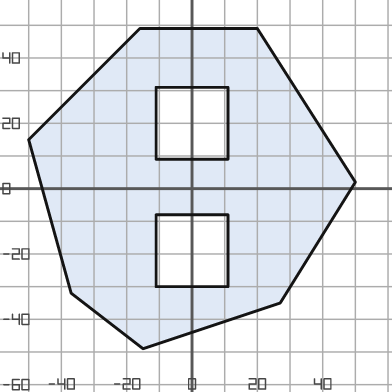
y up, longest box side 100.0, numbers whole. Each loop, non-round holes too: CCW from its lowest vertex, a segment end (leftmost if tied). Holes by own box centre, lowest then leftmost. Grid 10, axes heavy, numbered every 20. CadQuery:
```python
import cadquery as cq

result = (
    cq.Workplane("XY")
    .moveTo(-15.0, -49.0)
    .lineTo(27.0, -35.0)
    .lineTo(50.0, 2.0)
    .lineTo(20.0, 49.0)
    .lineTo(-16.0, 49.0)
    .lineTo(-50.0, 15.0)
    .lineTo(-37.0, -32.0)
    .close()
    .moveTo(-11.0, -30.0)
    .lineTo(11.0, -30.0)
    .lineTo(11.0, -8.0)
    .lineTo(-11.0, -8.0)
    .close()
    .moveTo(-11.0, 9.0)
    .lineTo(11.0, 9.0)
    .lineTo(11.0, 31.0)
    .lineTo(-11.0, 31.0)
    .close()
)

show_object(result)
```